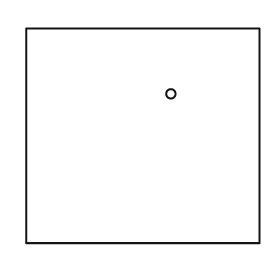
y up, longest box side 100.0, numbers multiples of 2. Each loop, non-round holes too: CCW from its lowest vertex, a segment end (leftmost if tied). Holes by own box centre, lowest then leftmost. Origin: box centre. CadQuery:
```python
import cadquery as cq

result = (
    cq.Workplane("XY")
    .moveTo(-50.0, -46.0)
    .lineTo(50.0, -46.0)
    .lineTo(50.0, 46.0)
    .lineTo(-50.0, 46.0)
    .close()
    .moveTo(12.0, 18.0)
    .circle(2.0)
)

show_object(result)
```